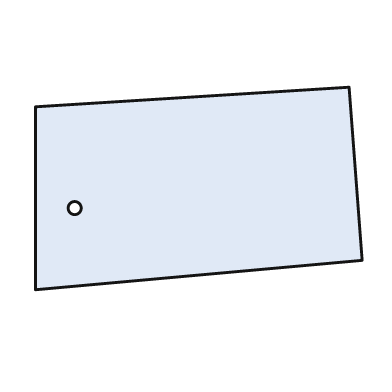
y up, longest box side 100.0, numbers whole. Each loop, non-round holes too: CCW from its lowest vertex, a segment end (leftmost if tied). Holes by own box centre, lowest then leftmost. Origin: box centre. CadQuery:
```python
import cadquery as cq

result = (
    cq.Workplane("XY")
    .moveTo(-50.0, -31.0)
    .lineTo(50.0, -22.0)
    .lineTo(46.0, 31.0)
    .lineTo(-50.0, 25.0)
    .close()
    .moveTo(-38.0, -6.0)
    .circle(2.0)
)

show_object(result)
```